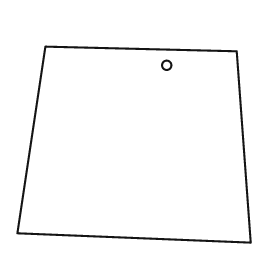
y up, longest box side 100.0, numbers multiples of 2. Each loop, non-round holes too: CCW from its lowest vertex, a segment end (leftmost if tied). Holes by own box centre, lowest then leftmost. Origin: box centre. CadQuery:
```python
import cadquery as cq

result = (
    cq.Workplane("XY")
    .moveTo(50.0, -42.0)
    .lineTo(44.0, 40.0)
    .lineTo(-38.0, 42.0)
    .lineTo(-50.0, -38.0)
    .close()
    .moveTo(14.0, 34.0)
    .circle(2.0)
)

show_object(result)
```